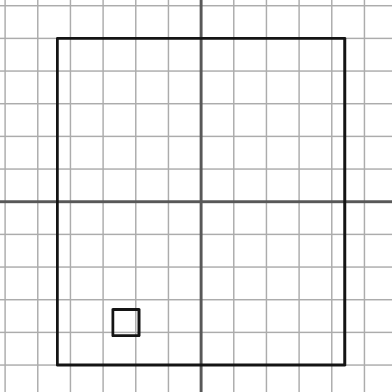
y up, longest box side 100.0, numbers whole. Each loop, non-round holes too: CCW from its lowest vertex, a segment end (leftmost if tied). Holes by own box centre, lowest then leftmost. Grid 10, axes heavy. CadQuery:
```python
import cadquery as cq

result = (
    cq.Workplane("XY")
    .moveTo(-44.0, -50.0)
    .lineTo(44.0, -50.0)
    .lineTo(44.0, 50.0)
    .lineTo(-44.0, 50.0)
    .close()
    .moveTo(-27.0, -41.0)
    .lineTo(-19.0, -41.0)
    .lineTo(-19.0, -33.0)
    .lineTo(-27.0, -33.0)
    .close()
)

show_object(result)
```